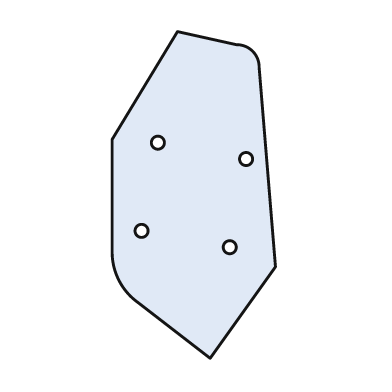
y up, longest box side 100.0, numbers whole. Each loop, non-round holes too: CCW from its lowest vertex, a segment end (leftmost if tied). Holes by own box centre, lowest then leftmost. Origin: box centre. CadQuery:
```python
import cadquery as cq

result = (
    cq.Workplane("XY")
    .moveTo(5.0, -50.0)
    .lineTo(25.0, -22.0)
    .lineTo(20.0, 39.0)
    .threePointArc((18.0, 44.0), (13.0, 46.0))
    .lineTo(-5.0, 50.0)
    .lineTo(-25.0, 17.0)
    .lineTo(-25.0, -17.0)
    .threePointArc((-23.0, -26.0), (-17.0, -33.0))
    .close()
    .moveTo(11.0, -16.0)
    .circle(2.0)
    .moveTo(-16.0, -11.0)
    .circle(2.0)
    .moveTo(16.0, 11.0)
    .circle(2.0)
    .moveTo(-11.0, 16.0)
    .circle(2.0)
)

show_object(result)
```